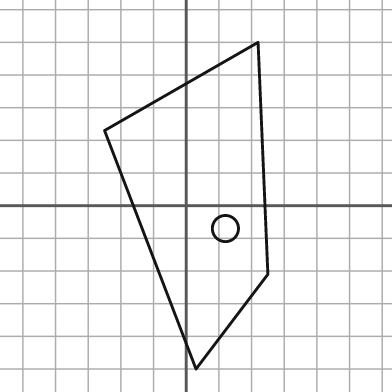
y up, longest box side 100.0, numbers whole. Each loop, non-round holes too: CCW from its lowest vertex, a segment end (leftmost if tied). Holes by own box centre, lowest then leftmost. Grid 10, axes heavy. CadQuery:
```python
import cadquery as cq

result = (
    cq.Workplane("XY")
    .moveTo(3.0, -50.0)
    .lineTo(25.0, -21.0)
    .lineTo(22.0, 50.0)
    .lineTo(-25.0, 23.0)
    .close()
    .moveTo(12.0, -7.0)
    .circle(4.0)
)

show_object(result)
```